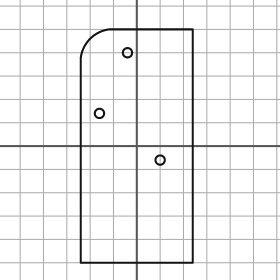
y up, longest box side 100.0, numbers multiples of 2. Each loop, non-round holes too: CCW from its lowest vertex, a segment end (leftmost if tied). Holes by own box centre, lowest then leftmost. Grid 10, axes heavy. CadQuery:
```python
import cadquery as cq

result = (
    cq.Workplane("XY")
    .moveTo(-24.0, -50.0)
    .lineTo(24.0, -50.0)
    .lineTo(24.0, 50.0)
    .lineTo(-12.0, 50.0)
    .threePointArc((-20.0, 46.0), (-24.0, 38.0))
    .close()
    .moveTo(10.0, -6.0)
    .circle(2.0)
    .moveTo(-16.0, 14.0)
    .circle(2.0)
    .moveTo(-4.0, 40.0)
    .circle(2.0)
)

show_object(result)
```